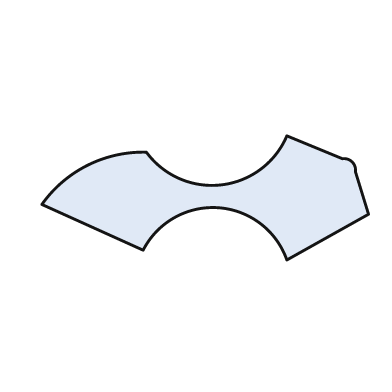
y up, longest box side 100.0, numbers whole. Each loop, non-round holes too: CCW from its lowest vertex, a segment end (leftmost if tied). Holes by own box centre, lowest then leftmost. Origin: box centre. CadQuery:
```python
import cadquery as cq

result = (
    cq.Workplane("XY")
    .moveTo(25.0, -19.0)
    .lineTo(50.0, -5.0)
    .lineTo(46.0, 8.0)
    .threePointArc((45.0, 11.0), (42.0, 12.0))
    .lineTo(25.0, 19.0)
    .threePointArc((5.0, 4.0), (-18.0, 14.0))
    .threePointArc((-36.0, 10.0), (-50.0, -2.0))
    .lineTo(-19.0, -16.0)
    .threePointArc((4.0, -3.0), (25.0, -19.0))
    .close()
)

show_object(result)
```